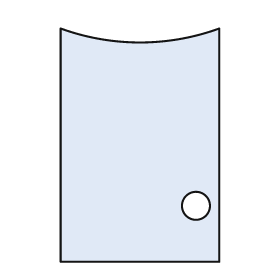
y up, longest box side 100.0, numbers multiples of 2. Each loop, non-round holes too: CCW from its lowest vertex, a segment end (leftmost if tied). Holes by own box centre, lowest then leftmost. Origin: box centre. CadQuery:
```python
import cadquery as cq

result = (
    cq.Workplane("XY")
    .moveTo(-34.0, -50.0)
    .lineTo(34.0, -50.0)
    .lineTo(34.0, 50.0)
    .threePointArc((0.0, 44.0), (-34.0, 50.0))
    .close()
    .moveTo(24.0, -26.0)
    .circle(6.0)
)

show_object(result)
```